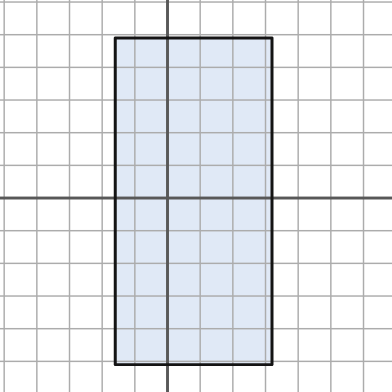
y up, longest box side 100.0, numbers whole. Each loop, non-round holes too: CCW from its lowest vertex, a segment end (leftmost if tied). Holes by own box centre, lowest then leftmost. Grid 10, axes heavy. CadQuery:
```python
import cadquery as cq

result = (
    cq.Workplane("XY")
    .moveTo(-16.0, -51.0)
    .lineTo(32.0, -51.0)
    .lineTo(32.0, 49.0)
    .lineTo(-16.0, 49.0)
    .close()
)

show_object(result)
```